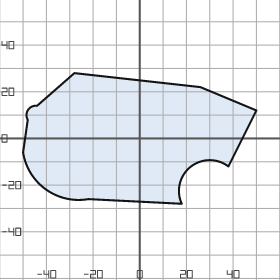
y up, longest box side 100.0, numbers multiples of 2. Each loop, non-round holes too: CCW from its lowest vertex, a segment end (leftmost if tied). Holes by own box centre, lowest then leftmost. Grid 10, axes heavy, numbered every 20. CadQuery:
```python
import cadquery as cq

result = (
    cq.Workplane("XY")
    .moveTo(18.0, -28.0)
    .threePointArc((22.0, -12.0), (38.0, -12.0))
    .lineTo(50.0, 12.0)
    .lineTo(26.0, 22.0)
    .lineTo(-28.0, 28.0)
    .lineTo(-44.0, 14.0)
    .threePointArc((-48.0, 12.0), (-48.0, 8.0))
    .lineTo(-50.0, -6.0)
    .threePointArc((-40.0, -22.0), (-22.0, -26.0))
    .close()
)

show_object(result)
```